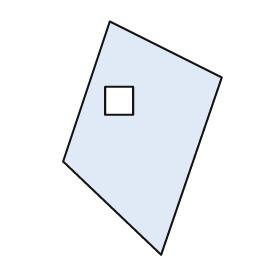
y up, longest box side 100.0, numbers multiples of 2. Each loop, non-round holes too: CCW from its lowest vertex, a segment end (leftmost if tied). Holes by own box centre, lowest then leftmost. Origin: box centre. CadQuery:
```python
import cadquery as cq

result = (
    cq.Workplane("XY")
    .moveTo(8.0, -50.0)
    .lineTo(34.0, 26.0)
    .lineTo(-14.0, 50.0)
    .lineTo(-34.0, -10.0)
    .close()
    .moveTo(-16.0, 10.0)
    .lineTo(-4.0, 10.0)
    .lineTo(-4.0, 22.0)
    .lineTo(-16.0, 22.0)
    .close()
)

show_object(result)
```